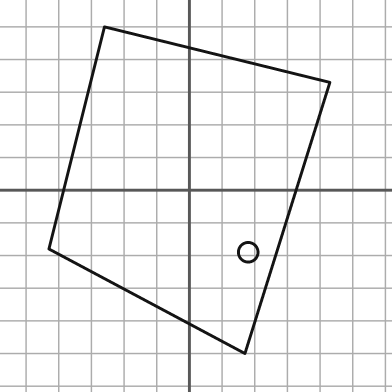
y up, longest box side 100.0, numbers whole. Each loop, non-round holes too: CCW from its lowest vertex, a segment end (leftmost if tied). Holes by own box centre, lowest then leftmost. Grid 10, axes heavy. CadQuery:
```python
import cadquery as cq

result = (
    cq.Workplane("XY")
    .moveTo(17.0, -50.0)
    .lineTo(43.0, 33.0)
    .lineTo(-26.0, 50.0)
    .lineTo(-43.0, -18.0)
    .close()
    .moveTo(18.0, -19.0)
    .circle(3.0)
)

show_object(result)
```